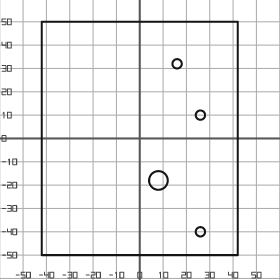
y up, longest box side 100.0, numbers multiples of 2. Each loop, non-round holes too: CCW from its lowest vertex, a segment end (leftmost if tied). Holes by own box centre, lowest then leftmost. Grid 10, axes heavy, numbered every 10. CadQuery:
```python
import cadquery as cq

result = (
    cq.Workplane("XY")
    .moveTo(-42.0, -50.0)
    .lineTo(42.0, -50.0)
    .lineTo(42.0, 50.0)
    .lineTo(-42.0, 50.0)
    .close()
    .moveTo(26.0, -40.0)
    .circle(2.0)
    .moveTo(8.0, -18.0)
    .circle(4.0)
    .moveTo(26.0, 10.0)
    .circle(2.0)
    .moveTo(16.0, 32.0)
    .circle(2.0)
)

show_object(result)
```